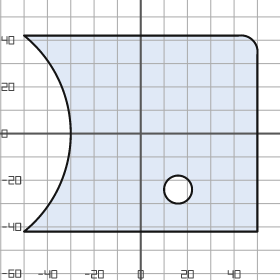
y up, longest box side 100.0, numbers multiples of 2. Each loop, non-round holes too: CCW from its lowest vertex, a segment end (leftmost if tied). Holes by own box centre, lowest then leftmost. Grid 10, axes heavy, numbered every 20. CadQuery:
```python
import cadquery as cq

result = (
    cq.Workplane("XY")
    .moveTo(-50.0, -42.0)
    .lineTo(50.0, -42.0)
    .lineTo(50.0, 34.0)
    .threePointArc((48.0, 40.0), (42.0, 42.0))
    .lineTo(-50.0, 42.0)
    .threePointArc((-30.0, 0.0), (-50.0, -42.0))
    .close()
    .moveTo(16.0, -24.0)
    .circle(6.0)
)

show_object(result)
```